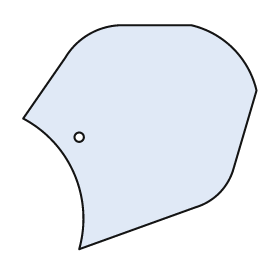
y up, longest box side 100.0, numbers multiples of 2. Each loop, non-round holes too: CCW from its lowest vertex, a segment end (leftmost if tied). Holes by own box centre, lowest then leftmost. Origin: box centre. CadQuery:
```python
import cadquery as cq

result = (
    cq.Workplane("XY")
    .moveTo(-26.0, -48.0)
    .lineTo(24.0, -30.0)
    .threePointArc((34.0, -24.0), (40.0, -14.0))
    .lineTo(50.0, 20.0)
    .threePointArc((40.0, 38.0), (22.0, 48.0))
    .lineTo(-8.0, 48.0)
    .threePointArc((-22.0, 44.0), (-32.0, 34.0))
    .lineTo(-50.0, 8.0)
    .threePointArc((-28.0, -16.0), (-26.0, -48.0))
    .close()
    .moveTo(-26.0, 0.0)
    .circle(2.0)
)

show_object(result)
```